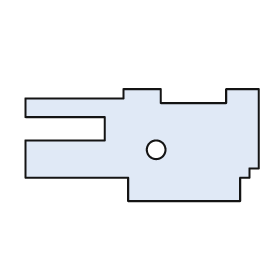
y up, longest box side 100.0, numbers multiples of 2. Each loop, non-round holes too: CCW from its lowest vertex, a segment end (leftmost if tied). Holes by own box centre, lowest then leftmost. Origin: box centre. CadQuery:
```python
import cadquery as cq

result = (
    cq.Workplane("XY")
    .moveTo(-6.0, -24.0)
    .lineTo(42.0, -24.0)
    .lineTo(42.0, -14.0)
    .lineTo(46.0, -14.0)
    .lineTo(46.0, -10.0)
    .lineTo(50.0, -10.0)
    .lineTo(50.0, 24.0)
    .lineTo(36.0, 24.0)
    .lineTo(36.0, 18.0)
    .lineTo(8.0, 18.0)
    .lineTo(8.0, 24.0)
    .lineTo(-8.0, 24.0)
    .lineTo(-8.0, 20.0)
    .lineTo(-50.0, 20.0)
    .lineTo(-50.0, 12.0)
    .lineTo(-16.0, 12.0)
    .lineTo(-16.0, 2.0)
    .lineTo(-50.0, 2.0)
    .lineTo(-50.0, -14.0)
    .lineTo(-6.0, -14.0)
    .close()
    .moveTo(6.0, -2.0)
    .circle(4.0)
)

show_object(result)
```